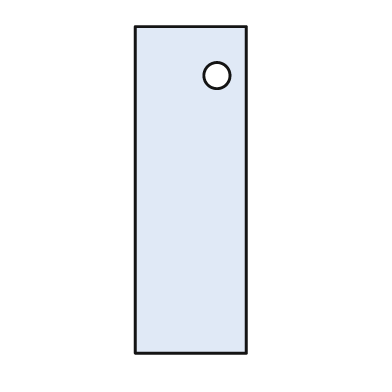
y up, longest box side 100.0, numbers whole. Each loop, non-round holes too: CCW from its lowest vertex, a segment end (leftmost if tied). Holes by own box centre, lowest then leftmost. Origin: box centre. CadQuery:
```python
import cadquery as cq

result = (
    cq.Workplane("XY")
    .moveTo(-17.0, -50.0)
    .lineTo(17.0, -50.0)
    .lineTo(17.0, 50.0)
    .lineTo(-17.0, 50.0)
    .close()
    .moveTo(8.0, 35.0)
    .circle(4.0)
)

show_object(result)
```